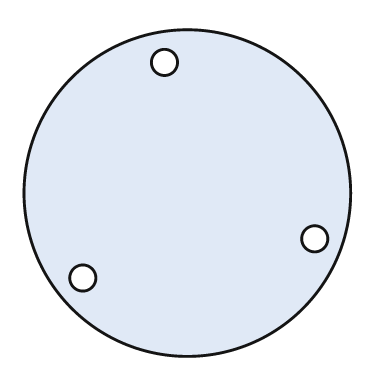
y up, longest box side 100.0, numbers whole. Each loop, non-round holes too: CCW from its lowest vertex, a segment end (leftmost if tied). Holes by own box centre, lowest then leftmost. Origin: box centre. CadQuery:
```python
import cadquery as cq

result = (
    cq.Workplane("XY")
    .moveTo(0.0, 0.0)
    .circle(50.0)
    .moveTo(-32.0, -26.0)
    .circle(4.0)
    .moveTo(39.0, -14.0)
    .circle(4.0)
    .moveTo(-7.0, 40.0)
    .circle(4.0)
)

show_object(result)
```